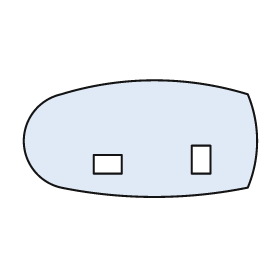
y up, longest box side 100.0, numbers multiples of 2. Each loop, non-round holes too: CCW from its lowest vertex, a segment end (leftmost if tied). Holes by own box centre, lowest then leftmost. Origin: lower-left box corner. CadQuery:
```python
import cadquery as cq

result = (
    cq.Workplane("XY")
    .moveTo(16.0, 4.0)
    .threePointArc((56.0, 0.0), (96.0, 4.0))
    .threePointArc((100.0, 24.0), (96.0, 44.0))
    .threePointArc((56.0, 50.0), (16.0, 44.0))
    .threePointArc((0.0, 24.0), (16.0, 4.0))
    .close()
    .moveTo(30.0, 10.0)
    .lineTo(42.0, 10.0)
    .lineTo(42.0, 18.0)
    .lineTo(30.0, 18.0)
    .close()
    .moveTo(72.0, 10.0)
    .lineTo(80.0, 10.0)
    .lineTo(80.0, 22.0)
    .lineTo(72.0, 22.0)
    .close()
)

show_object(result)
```